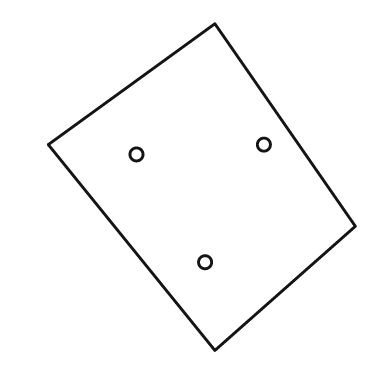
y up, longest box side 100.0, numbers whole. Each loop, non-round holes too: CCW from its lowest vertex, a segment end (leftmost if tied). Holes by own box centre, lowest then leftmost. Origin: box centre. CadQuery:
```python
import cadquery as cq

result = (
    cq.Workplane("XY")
    .moveTo(4.0, -50.0)
    .lineTo(47.0, -12.0)
    .lineTo(4.0, 50.0)
    .lineTo(-47.0, 13.0)
    .close()
    .moveTo(1.0, -23.0)
    .circle(2.0)
    .moveTo(-20.0, 10.0)
    .circle(2.0)
    .moveTo(19.0, 13.0)
    .circle(2.0)
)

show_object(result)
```